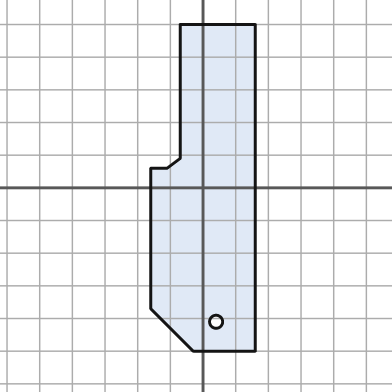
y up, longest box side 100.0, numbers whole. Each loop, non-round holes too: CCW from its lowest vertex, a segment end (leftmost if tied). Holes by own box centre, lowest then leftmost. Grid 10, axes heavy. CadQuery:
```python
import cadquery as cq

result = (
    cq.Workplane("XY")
    .moveTo(-3.0, -50.0)
    .lineTo(16.0, -50.0)
    .lineTo(16.0, 50.0)
    .lineTo(-7.0, 50.0)
    .lineTo(-7.0, 9.0)
    .lineTo(-11.0, 6.0)
    .lineTo(-16.0, 6.0)
    .lineTo(-16.0, -37.0)
    .close()
    .moveTo(4.0, -41.0)
    .circle(2.0)
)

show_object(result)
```